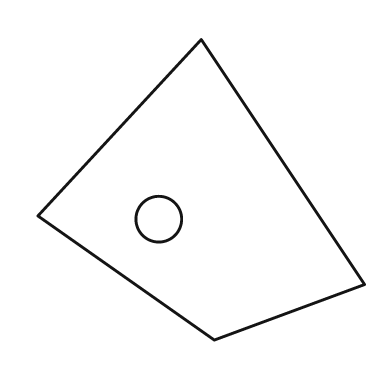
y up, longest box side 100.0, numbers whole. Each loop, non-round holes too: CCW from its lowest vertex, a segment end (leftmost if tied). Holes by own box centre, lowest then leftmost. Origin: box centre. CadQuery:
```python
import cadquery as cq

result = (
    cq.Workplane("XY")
    .moveTo(4.0, -46.0)
    .lineTo(50.0, -29.0)
    .lineTo(0.0, 46.0)
    .lineTo(-50.0, -8.0)
    .close()
    .moveTo(-13.0, -9.0)
    .circle(7.0)
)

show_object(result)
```